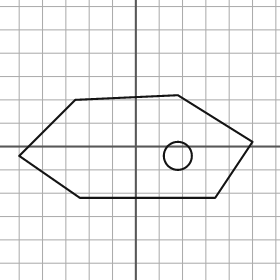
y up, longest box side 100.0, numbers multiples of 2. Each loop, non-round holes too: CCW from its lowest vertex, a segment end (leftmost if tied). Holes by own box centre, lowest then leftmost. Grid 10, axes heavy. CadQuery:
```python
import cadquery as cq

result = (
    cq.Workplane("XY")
    .moveTo(-24.0, -22.0)
    .lineTo(34.0, -22.0)
    .lineTo(50.0, 2.0)
    .lineTo(18.0, 22.0)
    .lineTo(-26.0, 20.0)
    .lineTo(-50.0, -4.0)
    .close()
    .moveTo(18.0, -4.0)
    .circle(6.0)
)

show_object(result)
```